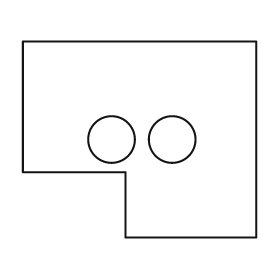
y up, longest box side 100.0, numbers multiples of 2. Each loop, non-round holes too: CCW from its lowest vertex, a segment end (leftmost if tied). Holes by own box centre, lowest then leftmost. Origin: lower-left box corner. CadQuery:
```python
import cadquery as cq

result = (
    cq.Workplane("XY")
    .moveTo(44.0, 0.0)
    .lineTo(100.0, 0.0)
    .lineTo(100.0, 84.0)
    .lineTo(0.0, 84.0)
    .lineTo(0.0, 28.0)
    .lineTo(44.0, 28.0)
    .close()
    .moveTo(38.0, 42.0)
    .circle(10.0)
    .moveTo(64.0, 42.0)
    .circle(10.0)
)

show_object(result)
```